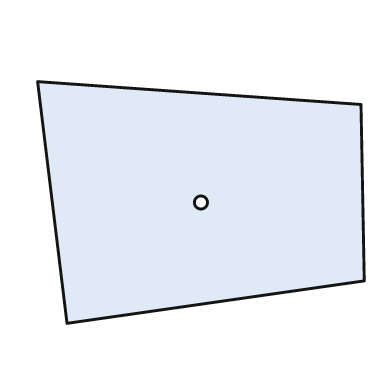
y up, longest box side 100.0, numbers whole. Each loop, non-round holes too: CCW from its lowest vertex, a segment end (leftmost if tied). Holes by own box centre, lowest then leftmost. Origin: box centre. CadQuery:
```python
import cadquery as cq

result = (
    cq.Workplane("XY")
    .moveTo(-41.0, -37.0)
    .lineTo(50.0, -24.0)
    .lineTo(49.0, 30.0)
    .lineTo(-50.0, 37.0)
    .close()
    .moveTo(0.0, 0.0)
    .circle(2.0)
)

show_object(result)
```